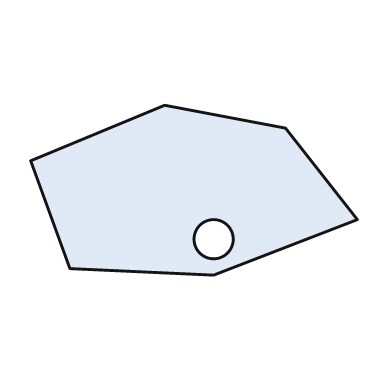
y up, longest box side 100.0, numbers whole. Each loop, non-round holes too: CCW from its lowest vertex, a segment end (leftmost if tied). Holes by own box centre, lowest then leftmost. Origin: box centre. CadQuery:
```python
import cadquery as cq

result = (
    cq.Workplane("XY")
    .moveTo(6.0, -26.0)
    .lineTo(50.0, -9.0)
    .lineTo(28.0, 19.0)
    .lineTo(-9.0, 26.0)
    .lineTo(-50.0, 9.0)
    .lineTo(-38.0, -24.0)
    .close()
    .moveTo(6.0, -15.0)
    .circle(6.0)
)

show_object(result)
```